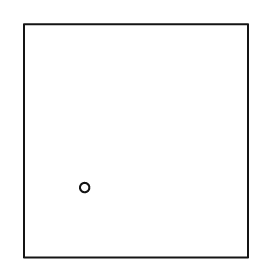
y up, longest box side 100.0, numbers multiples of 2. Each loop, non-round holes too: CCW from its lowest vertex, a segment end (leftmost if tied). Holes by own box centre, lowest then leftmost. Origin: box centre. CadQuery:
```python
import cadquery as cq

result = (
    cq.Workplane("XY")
    .moveTo(-48.0, -50.0)
    .lineTo(48.0, -50.0)
    .lineTo(48.0, 50.0)
    .lineTo(-48.0, 50.0)
    .close()
    .moveTo(-22.0, -20.0)
    .circle(2.0)
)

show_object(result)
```